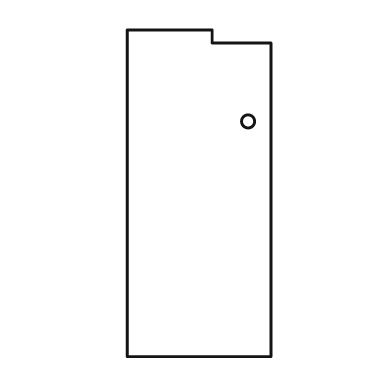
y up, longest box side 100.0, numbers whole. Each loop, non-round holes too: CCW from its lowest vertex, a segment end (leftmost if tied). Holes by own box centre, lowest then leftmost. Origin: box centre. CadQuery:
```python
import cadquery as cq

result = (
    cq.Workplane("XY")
    .moveTo(-22.0, -50.0)
    .lineTo(22.0, -50.0)
    .lineTo(22.0, 46.0)
    .lineTo(4.0, 46.0)
    .lineTo(4.0, 50.0)
    .lineTo(-22.0, 50.0)
    .close()
    .moveTo(15.0, 22.0)
    .circle(2.0)
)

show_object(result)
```